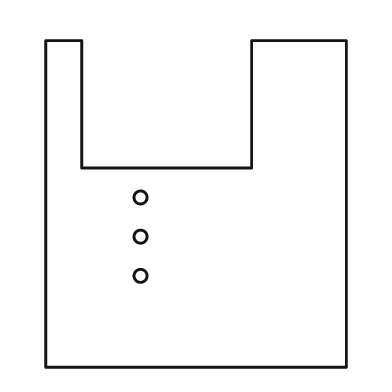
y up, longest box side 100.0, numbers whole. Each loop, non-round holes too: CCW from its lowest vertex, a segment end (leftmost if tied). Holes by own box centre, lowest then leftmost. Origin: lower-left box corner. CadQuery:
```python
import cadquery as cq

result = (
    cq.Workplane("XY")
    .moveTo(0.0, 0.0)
    .lineTo(92.0, 0.0)
    .lineTo(92.0, 100.0)
    .lineTo(63.0, 100.0)
    .lineTo(63.0, 61.0)
    .lineTo(11.0, 61.0)
    .lineTo(11.0, 100.0)
    .lineTo(0.0, 100.0)
    .close()
    .moveTo(29.0, 28.0)
    .circle(2.0)
    .moveTo(29.0, 40.0)
    .circle(2.0)
    .moveTo(29.0, 52.0)
    .circle(2.0)
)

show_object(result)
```